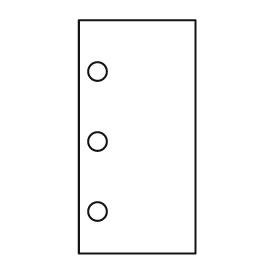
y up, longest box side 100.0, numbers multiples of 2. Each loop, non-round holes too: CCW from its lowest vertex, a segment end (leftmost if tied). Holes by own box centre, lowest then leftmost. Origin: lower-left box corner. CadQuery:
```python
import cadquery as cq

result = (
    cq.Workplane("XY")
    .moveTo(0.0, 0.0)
    .lineTo(50.0, 0.0)
    .lineTo(50.0, 100.0)
    .lineTo(0.0, 100.0)
    .close()
    .moveTo(8.0, 18.0)
    .circle(4.0)
    .moveTo(8.0, 48.0)
    .circle(4.0)
    .moveTo(8.0, 78.0)
    .circle(4.0)
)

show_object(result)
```